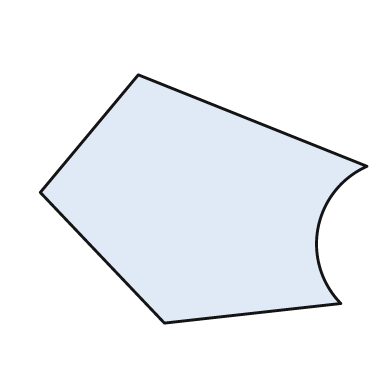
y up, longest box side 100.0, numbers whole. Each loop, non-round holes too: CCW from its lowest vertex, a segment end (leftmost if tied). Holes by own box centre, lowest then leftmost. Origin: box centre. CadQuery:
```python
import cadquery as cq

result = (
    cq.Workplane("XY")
    .moveTo(-12.0, -38.0)
    .lineTo(42.0, -32.0)
    .threePointArc((35.0, -9.0), (50.0, 10.0))
    .lineTo(-20.0, 38.0)
    .lineTo(-50.0, 2.0)
    .close()
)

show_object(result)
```